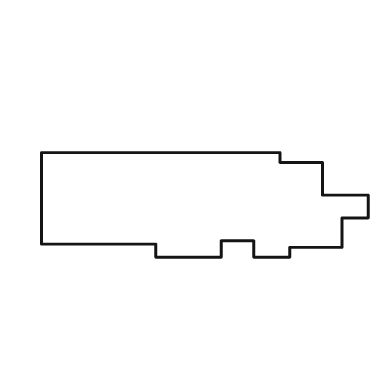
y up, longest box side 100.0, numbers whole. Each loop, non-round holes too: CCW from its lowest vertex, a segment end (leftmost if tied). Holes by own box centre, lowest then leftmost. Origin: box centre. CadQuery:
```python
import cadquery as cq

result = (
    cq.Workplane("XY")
    .moveTo(-15.0, -16.0)
    .lineTo(5.0, -16.0)
    .lineTo(5.0, -11.0)
    .lineTo(15.0, -11.0)
    .lineTo(15.0, -16.0)
    .lineTo(26.0, -16.0)
    .lineTo(26.0, -13.0)
    .lineTo(42.0, -13.0)
    .lineTo(42.0, -4.0)
    .lineTo(50.0, -4.0)
    .lineTo(50.0, 3.0)
    .lineTo(36.0, 3.0)
    .lineTo(36.0, 13.0)
    .lineTo(23.0, 13.0)
    .lineTo(23.0, 16.0)
    .lineTo(-50.0, 16.0)
    .lineTo(-50.0, -12.0)
    .lineTo(-15.0, -12.0)
    .close()
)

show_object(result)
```